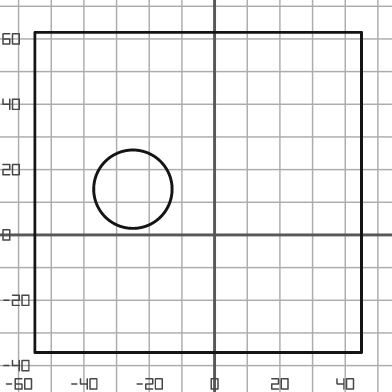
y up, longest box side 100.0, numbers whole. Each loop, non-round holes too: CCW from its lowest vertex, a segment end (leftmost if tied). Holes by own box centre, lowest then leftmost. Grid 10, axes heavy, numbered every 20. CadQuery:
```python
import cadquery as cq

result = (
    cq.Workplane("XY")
    .moveTo(-55.0, -36.0)
    .lineTo(45.0, -36.0)
    .lineTo(45.0, 62.0)
    .lineTo(-55.0, 62.0)
    .close()
    .moveTo(-25.0, 14.0)
    .circle(12.0)
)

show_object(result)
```